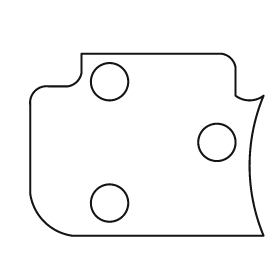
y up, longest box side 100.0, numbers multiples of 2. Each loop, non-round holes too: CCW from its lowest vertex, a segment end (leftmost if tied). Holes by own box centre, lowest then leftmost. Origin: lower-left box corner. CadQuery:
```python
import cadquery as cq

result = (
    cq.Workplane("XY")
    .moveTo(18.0, 0.0)
    .lineTo(100.0, 0.0)
    .threePointArc((94.0, 30.0), (100.0, 60.0))
    .threePointArc((94.0, 58.0), (88.0, 60.0))
    .lineTo(88.0, 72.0)
    .threePointArc((86.0, 76.0), (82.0, 78.0))
    .lineTo(22.0, 78.0)
    .lineTo(22.0, 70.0)
    .threePointArc((20.0, 66.0), (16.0, 64.0))
    .lineTo(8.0, 64.0)
    .threePointArc((2.0, 62.0), (0.0, 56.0))
    .lineTo(0.0, 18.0)
    .threePointArc((6.0, 6.0), (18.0, 0.0))
    .close()
    .moveTo(34.0, 14.0)
    .circle(8.0)
    .moveTo(80.0, 40.0)
    .circle(8.0)
    .moveTo(34.0, 66.0)
    .circle(8.0)
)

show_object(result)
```